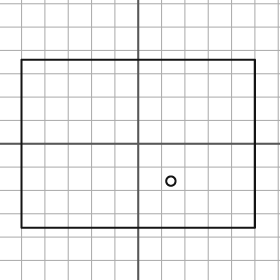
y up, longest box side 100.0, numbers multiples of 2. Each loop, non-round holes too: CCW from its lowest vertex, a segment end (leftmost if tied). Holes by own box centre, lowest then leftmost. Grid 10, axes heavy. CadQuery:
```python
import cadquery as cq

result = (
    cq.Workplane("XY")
    .moveTo(-50.0, -36.0)
    .lineTo(50.0, -36.0)
    .lineTo(50.0, 36.0)
    .lineTo(-50.0, 36.0)
    .close()
    .moveTo(14.0, -16.0)
    .circle(2.0)
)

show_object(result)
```